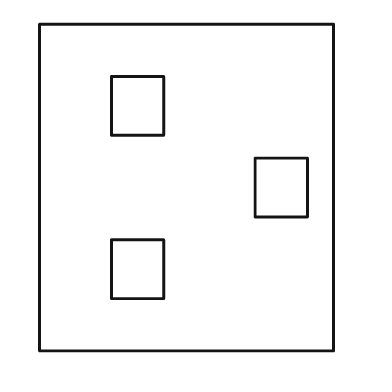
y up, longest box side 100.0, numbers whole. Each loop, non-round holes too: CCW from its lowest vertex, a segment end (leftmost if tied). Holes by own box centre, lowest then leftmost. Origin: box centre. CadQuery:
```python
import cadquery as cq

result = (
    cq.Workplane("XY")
    .moveTo(-45.0, -50.0)
    .lineTo(45.0, -50.0)
    .lineTo(45.0, 50.0)
    .lineTo(-45.0, 50.0)
    .close()
    .moveTo(-23.0, -34.0)
    .lineTo(-7.0, -34.0)
    .lineTo(-7.0, -16.0)
    .lineTo(-23.0, -16.0)
    .close()
    .moveTo(21.0, -9.0)
    .lineTo(37.0, -9.0)
    .lineTo(37.0, 9.0)
    .lineTo(21.0, 9.0)
    .close()
    .moveTo(-23.0, 16.0)
    .lineTo(-7.0, 16.0)
    .lineTo(-7.0, 34.0)
    .lineTo(-23.0, 34.0)
    .close()
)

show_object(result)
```